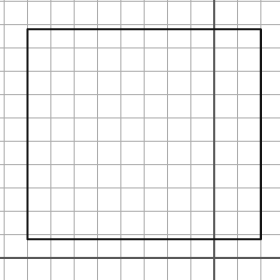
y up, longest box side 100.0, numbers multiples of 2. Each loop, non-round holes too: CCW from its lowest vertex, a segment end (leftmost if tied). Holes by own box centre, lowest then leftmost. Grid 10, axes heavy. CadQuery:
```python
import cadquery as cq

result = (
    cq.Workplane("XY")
    .moveTo(-80.0, 8.0)
    .lineTo(20.0, 8.0)
    .lineTo(20.0, 98.0)
    .lineTo(-80.0, 98.0)
    .close()
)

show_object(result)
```